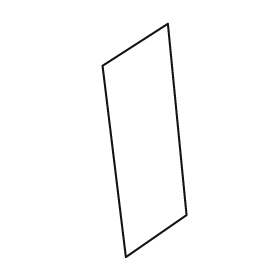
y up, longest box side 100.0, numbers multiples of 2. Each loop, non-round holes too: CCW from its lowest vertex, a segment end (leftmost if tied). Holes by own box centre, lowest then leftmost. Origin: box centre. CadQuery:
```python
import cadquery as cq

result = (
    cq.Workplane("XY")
    .moveTo(-8.0, -50.0)
    .lineTo(18.0, -32.0)
    .lineTo(10.0, 50.0)
    .lineTo(-18.0, 32.0)
    .close()
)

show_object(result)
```